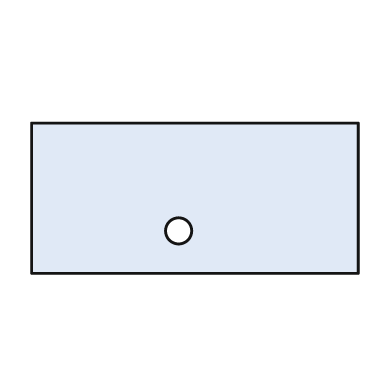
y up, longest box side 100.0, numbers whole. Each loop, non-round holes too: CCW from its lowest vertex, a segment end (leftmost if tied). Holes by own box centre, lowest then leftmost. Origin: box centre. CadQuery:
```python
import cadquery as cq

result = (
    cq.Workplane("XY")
    .moveTo(-50.0, -23.0)
    .lineTo(50.0, -23.0)
    .lineTo(50.0, 23.0)
    .lineTo(-50.0, 23.0)
    .close()
    .moveTo(-5.0, -10.0)
    .circle(4.0)
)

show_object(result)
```